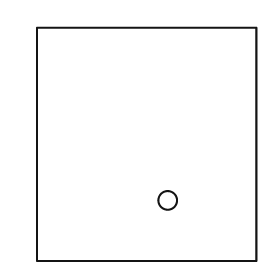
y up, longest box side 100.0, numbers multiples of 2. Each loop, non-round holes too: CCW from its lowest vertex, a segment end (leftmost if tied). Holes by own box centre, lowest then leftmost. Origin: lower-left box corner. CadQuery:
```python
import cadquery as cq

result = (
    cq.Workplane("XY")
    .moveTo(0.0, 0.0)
    .lineTo(94.0, 0.0)
    .lineTo(94.0, 100.0)
    .lineTo(0.0, 100.0)
    .close()
    .moveTo(56.0, 26.0)
    .circle(4.0)
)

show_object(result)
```